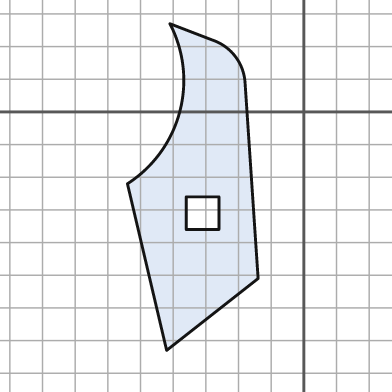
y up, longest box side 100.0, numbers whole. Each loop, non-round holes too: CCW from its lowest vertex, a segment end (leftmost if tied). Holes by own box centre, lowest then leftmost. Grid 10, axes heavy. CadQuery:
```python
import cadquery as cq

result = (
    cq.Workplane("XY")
    .moveTo(-42.0, -73.0)
    .lineTo(-14.0, -51.0)
    .lineTo(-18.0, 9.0)
    .threePointArc((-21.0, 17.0), (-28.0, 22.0))
    .lineTo(-41.0, 27.0)
    .threePointArc((-38.0, 0.0), (-54.0, -22.0))
    .close()
    .moveTo(-36.0, -36.0)
    .lineTo(-26.0, -36.0)
    .lineTo(-26.0, -26.0)
    .lineTo(-36.0, -26.0)
    .close()
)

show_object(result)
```